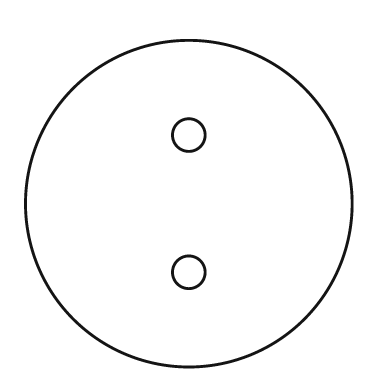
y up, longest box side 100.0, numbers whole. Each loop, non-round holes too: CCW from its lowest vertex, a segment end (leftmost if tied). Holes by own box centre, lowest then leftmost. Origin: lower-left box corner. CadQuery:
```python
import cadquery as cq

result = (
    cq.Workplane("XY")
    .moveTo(50.0, 50.0)
    .circle(50.0)
    .moveTo(50.0, 29.0)
    .circle(5.0)
    .moveTo(50.0, 71.0)
    .circle(5.0)
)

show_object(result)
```